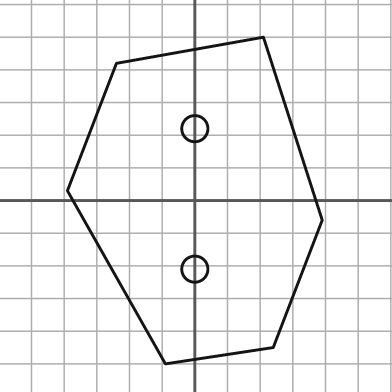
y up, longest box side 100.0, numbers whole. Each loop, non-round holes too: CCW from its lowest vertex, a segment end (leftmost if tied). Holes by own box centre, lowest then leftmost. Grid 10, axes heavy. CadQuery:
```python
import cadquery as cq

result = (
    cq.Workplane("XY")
    .moveTo(-9.0, -50.0)
    .lineTo(24.0, -45.0)
    .lineTo(39.0, -6.0)
    .lineTo(21.0, 50.0)
    .lineTo(-24.0, 42.0)
    .lineTo(-39.0, 3.0)
    .close()
    .moveTo(0.0, -21.0)
    .circle(4.0)
    .moveTo(0.0, 22.0)
    .circle(4.0)
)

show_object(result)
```